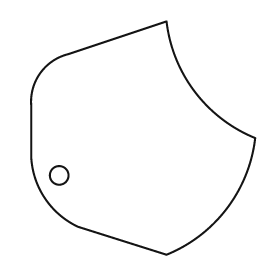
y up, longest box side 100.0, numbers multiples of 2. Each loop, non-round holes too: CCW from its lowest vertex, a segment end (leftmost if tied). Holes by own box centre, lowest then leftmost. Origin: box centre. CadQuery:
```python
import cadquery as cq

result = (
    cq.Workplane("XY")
    .moveTo(10.0, -50.0)
    .threePointArc((36.0, -30.0), (48.0, 0.0))
    .threePointArc((22.0, 20.0), (10.0, 50.0))
    .lineTo(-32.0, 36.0)
    .threePointArc((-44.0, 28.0), (-48.0, 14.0))
    .lineTo(-48.0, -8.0)
    .threePointArc((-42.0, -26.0), (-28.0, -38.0))
    .close()
    .moveTo(-36.0, -16.0)
    .circle(4.0)
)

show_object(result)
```